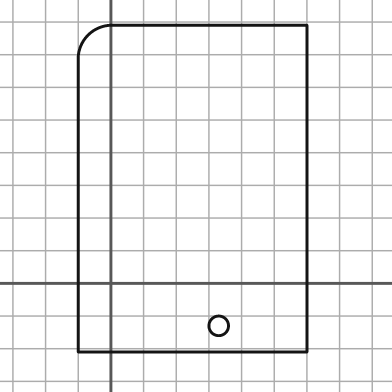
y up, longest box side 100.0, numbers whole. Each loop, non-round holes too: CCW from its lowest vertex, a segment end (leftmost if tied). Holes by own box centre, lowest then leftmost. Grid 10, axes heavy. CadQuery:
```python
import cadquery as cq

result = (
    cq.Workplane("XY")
    .moveTo(-10.0, -21.0)
    .lineTo(60.0, -21.0)
    .lineTo(60.0, 79.0)
    .lineTo(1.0, 79.0)
    .threePointArc((-7.0, 76.0), (-10.0, 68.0))
    .close()
    .moveTo(33.0, -13.0)
    .circle(3.0)
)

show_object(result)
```